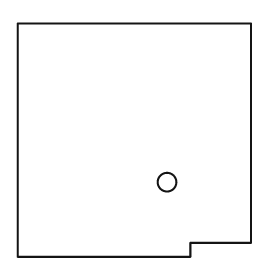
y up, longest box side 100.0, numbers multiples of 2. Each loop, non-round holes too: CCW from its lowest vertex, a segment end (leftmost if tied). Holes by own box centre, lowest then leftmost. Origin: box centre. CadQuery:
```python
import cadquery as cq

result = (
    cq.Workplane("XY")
    .moveTo(-50.0, -50.0)
    .lineTo(24.0, -50.0)
    .lineTo(24.0, -44.0)
    .lineTo(50.0, -44.0)
    .lineTo(50.0, 50.0)
    .lineTo(-50.0, 50.0)
    .close()
    .moveTo(14.0, -18.0)
    .circle(4.0)
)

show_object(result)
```